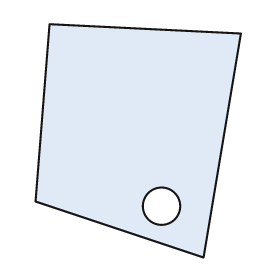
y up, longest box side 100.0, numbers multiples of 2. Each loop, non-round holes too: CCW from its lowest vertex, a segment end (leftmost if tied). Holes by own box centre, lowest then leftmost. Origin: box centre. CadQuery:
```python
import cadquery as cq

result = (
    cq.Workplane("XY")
    .moveTo(28.0, -50.0)
    .lineTo(44.0, 46.0)
    .lineTo(-38.0, 50.0)
    .lineTo(-44.0, -26.0)
    .close()
    .moveTo(10.0, -28.0)
    .circle(8.0)
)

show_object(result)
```